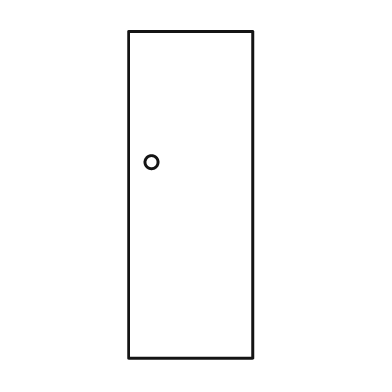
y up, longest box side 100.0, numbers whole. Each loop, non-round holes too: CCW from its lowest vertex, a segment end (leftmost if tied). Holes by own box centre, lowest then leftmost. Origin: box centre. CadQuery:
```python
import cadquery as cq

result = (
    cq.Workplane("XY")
    .moveTo(-19.0, -50.0)
    .lineTo(19.0, -50.0)
    .lineTo(19.0, 50.0)
    .lineTo(-19.0, 50.0)
    .close()
    .moveTo(-12.0, 10.0)
    .circle(2.0)
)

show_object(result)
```